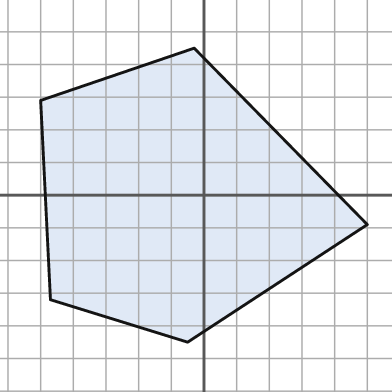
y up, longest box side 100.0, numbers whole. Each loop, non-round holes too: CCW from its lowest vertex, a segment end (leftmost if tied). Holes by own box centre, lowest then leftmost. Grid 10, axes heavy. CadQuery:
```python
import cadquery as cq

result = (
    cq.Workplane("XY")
    .moveTo(-5.0, -45.0)
    .lineTo(50.0, -9.0)
    .lineTo(-3.0, 45.0)
    .lineTo(-50.0, 29.0)
    .lineTo(-47.0, -32.0)
    .close()
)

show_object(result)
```